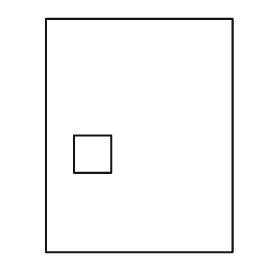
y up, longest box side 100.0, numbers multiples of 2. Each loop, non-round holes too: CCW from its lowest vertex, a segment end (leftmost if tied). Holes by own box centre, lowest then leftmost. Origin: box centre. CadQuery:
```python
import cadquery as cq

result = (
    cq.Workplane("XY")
    .moveTo(-40.0, -50.0)
    .lineTo(40.0, -50.0)
    .lineTo(40.0, 50.0)
    .lineTo(-40.0, 50.0)
    .close()
    .moveTo(-28.0, -16.0)
    .lineTo(-12.0, -16.0)
    .lineTo(-12.0, 0.0)
    .lineTo(-28.0, 0.0)
    .close()
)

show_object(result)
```